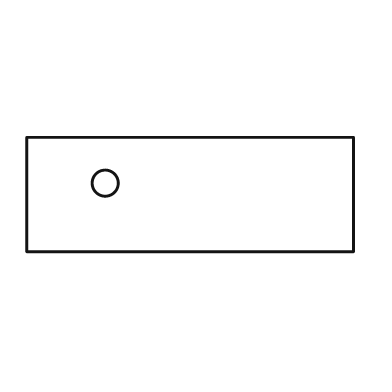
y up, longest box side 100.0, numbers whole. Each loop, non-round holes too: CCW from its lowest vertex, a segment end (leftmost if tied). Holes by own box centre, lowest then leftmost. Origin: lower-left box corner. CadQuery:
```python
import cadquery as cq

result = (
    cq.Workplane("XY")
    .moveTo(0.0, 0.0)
    .lineTo(100.0, 0.0)
    .lineTo(100.0, 35.0)
    .lineTo(0.0, 35.0)
    .close()
    .moveTo(24.0, 21.0)
    .circle(4.0)
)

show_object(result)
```